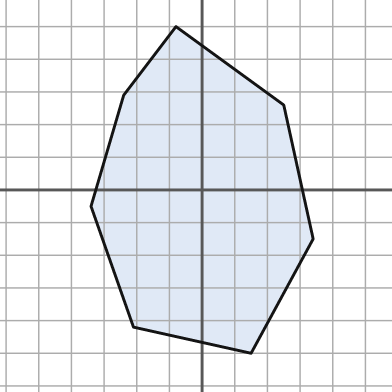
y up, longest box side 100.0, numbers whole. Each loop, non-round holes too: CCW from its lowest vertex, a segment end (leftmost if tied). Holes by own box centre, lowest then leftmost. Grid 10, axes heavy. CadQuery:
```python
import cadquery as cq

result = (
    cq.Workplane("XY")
    .moveTo(15.0, -50.0)
    .lineTo(34.0, -15.0)
    .lineTo(25.0, 26.0)
    .lineTo(-8.0, 50.0)
    .lineTo(-24.0, 29.0)
    .lineTo(-34.0, -5.0)
    .lineTo(-21.0, -42.0)
    .close()
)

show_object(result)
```